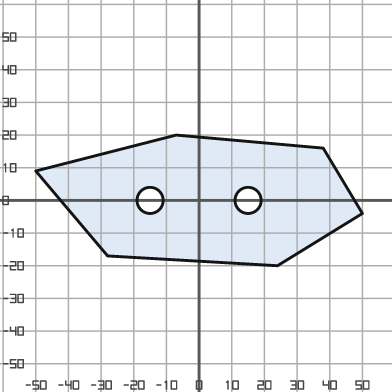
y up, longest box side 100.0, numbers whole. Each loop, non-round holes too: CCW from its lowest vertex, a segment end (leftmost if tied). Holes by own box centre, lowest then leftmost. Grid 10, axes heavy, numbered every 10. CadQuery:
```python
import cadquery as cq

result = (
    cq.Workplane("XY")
    .moveTo(24.0, -20.0)
    .lineTo(50.0, -4.0)
    .lineTo(38.0, 16.0)
    .lineTo(-7.0, 20.0)
    .lineTo(-50.0, 9.0)
    .lineTo(-28.0, -17.0)
    .close()
    .moveTo(-15.0, 0.0)
    .circle(4.0)
    .moveTo(15.0, 0.0)
    .circle(4.0)
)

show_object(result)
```